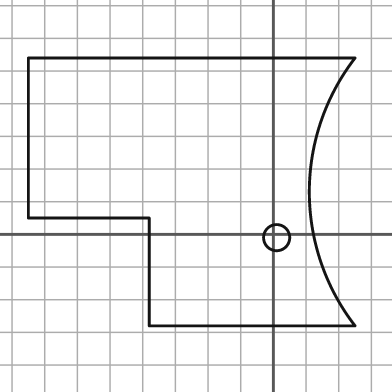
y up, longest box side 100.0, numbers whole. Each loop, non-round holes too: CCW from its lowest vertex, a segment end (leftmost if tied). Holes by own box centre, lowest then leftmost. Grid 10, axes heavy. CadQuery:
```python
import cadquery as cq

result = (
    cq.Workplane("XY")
    .moveTo(-38.0, -28.0)
    .lineTo(25.0, -28.0)
    .threePointArc((11.0, 13.0), (25.0, 54.0))
    .lineTo(-75.0, 54.0)
    .lineTo(-75.0, 5.0)
    .lineTo(-38.0, 5.0)
    .close()
    .moveTo(1.0, -1.0)
    .circle(4.0)
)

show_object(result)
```